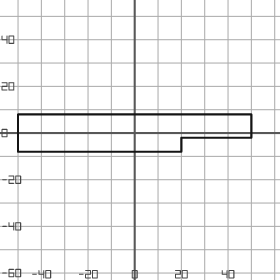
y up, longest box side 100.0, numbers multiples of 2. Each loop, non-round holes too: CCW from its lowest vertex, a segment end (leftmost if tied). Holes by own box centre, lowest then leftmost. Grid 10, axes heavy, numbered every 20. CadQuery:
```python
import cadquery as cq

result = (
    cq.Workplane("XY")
    .moveTo(-50.0, -8.0)
    .lineTo(20.0, -8.0)
    .lineTo(20.0, -2.0)
    .lineTo(50.0, -2.0)
    .lineTo(50.0, 8.0)
    .lineTo(-50.0, 8.0)
    .close()
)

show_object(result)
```